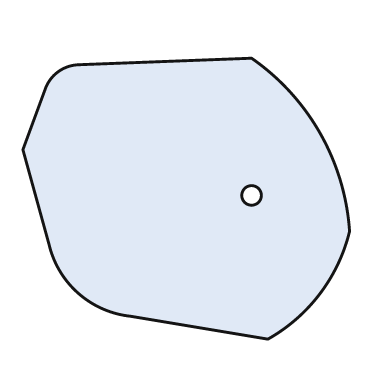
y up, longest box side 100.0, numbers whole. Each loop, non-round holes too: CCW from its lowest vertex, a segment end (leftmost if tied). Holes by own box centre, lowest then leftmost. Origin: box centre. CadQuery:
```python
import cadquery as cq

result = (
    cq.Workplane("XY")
    .moveTo(25.0, -43.0)
    .threePointArc((41.0, -29.0), (50.0, -10.0))
    .threePointArc((41.0, 20.0), (20.0, 43.0))
    .lineTo(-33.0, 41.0)
    .threePointArc((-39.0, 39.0), (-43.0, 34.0))
    .lineTo(-50.0, 15.0)
    .lineTo(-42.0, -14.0)
    .threePointArc((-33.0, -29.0), (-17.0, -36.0))
    .close()
    .moveTo(20.0, 1.0)
    .circle(3.0)
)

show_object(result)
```